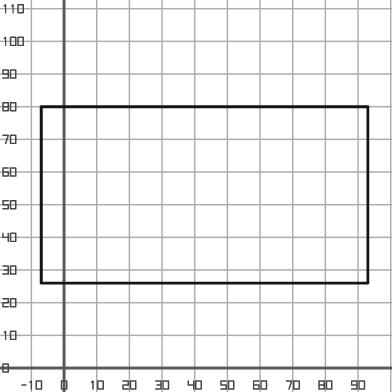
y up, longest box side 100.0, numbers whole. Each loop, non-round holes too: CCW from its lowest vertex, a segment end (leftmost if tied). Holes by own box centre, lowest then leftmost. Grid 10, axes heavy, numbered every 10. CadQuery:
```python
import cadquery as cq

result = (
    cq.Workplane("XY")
    .moveTo(-7.0, 26.0)
    .lineTo(93.0, 26.0)
    .lineTo(93.0, 80.0)
    .lineTo(-7.0, 80.0)
    .close()
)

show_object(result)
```